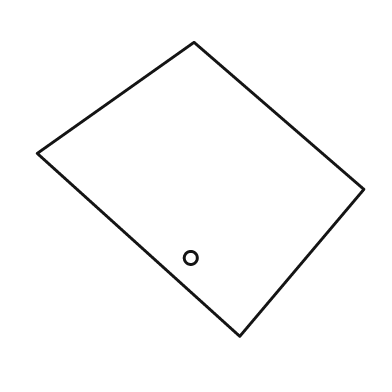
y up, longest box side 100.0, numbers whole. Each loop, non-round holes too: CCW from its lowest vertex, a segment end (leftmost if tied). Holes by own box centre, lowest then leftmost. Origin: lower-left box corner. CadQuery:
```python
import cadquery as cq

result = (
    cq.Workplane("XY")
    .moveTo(62.0, 0.0)
    .lineTo(100.0, 45.0)
    .lineTo(48.0, 90.0)
    .lineTo(0.0, 56.0)
    .close()
    .moveTo(47.0, 24.0)
    .circle(2.0)
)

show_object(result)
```